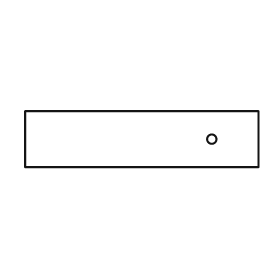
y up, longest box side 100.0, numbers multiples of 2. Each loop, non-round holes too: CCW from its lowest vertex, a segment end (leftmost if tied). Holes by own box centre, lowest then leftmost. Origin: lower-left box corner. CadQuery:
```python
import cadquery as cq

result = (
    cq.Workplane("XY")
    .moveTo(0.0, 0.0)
    .lineTo(100.0, 0.0)
    .lineTo(100.0, 24.0)
    .lineTo(0.0, 24.0)
    .close()
    .moveTo(80.0, 12.0)
    .circle(2.0)
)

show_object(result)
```